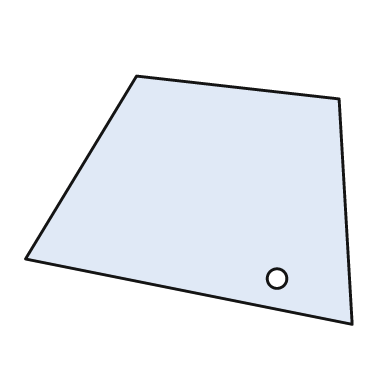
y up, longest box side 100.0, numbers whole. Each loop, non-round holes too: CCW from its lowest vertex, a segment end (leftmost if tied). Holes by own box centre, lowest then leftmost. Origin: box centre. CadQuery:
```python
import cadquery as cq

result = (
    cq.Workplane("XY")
    .moveTo(50.0, -38.0)
    .lineTo(46.0, 31.0)
    .lineTo(-16.0, 38.0)
    .lineTo(-50.0, -18.0)
    .close()
    .moveTo(27.0, -24.0)
    .circle(3.0)
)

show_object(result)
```